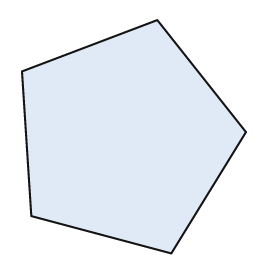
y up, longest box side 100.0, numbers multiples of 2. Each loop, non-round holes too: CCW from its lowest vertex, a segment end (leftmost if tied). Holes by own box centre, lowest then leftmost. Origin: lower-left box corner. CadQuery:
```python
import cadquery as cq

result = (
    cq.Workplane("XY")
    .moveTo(64.0, 0.0)
    .lineTo(96.0, 52.0)
    .lineTo(58.0, 100.0)
    .lineTo(0.0, 78.0)
    .lineTo(4.0, 16.0)
    .close()
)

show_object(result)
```